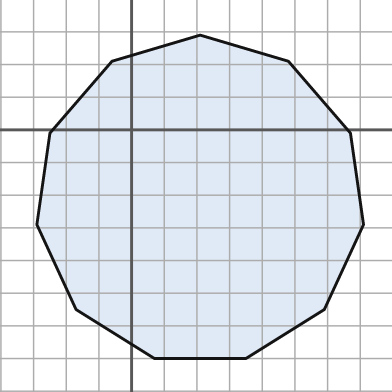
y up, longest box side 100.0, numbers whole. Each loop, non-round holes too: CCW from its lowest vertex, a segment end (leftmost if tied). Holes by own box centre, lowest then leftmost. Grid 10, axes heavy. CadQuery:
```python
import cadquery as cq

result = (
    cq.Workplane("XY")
    .moveTo(7.0, -70.0)
    .lineTo(35.0, -70.0)
    .lineTo(59.0, -55.0)
    .lineTo(71.0, -29.0)
    .lineTo(67.0, -1.0)
    .lineTo(48.0, 21.0)
    .lineTo(21.0, 29.0)
    .lineTo(-6.0, 21.0)
    .lineTo(-25.0, -1.0)
    .lineTo(-29.0, -29.0)
    .lineTo(-17.0, -55.0)
    .close()
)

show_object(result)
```